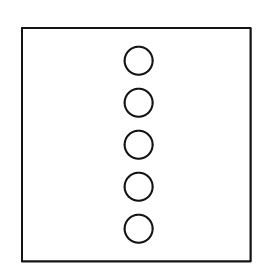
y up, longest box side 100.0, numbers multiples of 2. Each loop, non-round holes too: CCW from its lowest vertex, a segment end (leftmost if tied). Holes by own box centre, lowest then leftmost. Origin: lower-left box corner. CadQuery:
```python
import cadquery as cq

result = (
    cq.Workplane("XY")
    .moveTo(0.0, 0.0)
    .lineTo(98.0, 0.0)
    .lineTo(98.0, 100.0)
    .lineTo(0.0, 100.0)
    .close()
    .moveTo(50.0, 14.0)
    .circle(6.0)
    .moveTo(50.0, 32.0)
    .circle(6.0)
    .moveTo(50.0, 50.0)
    .circle(6.0)
    .moveTo(50.0, 68.0)
    .circle(6.0)
    .moveTo(50.0, 86.0)
    .circle(6.0)
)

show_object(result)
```